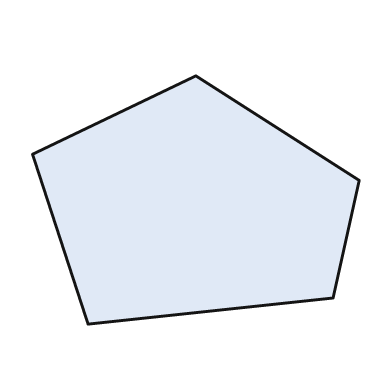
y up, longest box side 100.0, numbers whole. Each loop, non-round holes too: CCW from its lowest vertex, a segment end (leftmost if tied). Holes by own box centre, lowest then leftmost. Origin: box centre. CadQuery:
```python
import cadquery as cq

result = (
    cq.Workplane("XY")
    .moveTo(-33.0, -38.0)
    .lineTo(42.0, -30.0)
    .lineTo(50.0, 6.0)
    .lineTo(0.0, 38.0)
    .lineTo(-50.0, 14.0)
    .close()
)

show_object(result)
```